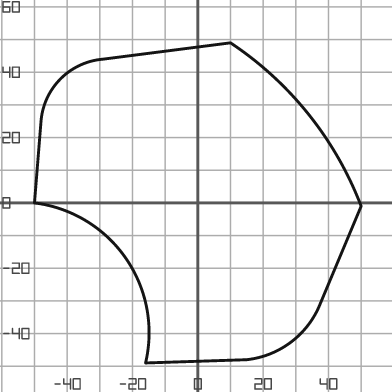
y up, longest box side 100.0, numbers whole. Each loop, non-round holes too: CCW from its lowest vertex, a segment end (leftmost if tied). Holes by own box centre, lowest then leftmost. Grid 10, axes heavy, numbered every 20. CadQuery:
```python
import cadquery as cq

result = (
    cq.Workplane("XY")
    .moveTo(-16.0, -49.0)
    .lineTo(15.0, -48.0)
    .threePointArc((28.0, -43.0), (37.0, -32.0))
    .lineTo(50.0, -1.0)
    .threePointArc((34.0, 27.0), (10.0, 49.0))
    .lineTo(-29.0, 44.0)
    .threePointArc((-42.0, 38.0), (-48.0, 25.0))
    .lineTo(-50.0, 0.0)
    .threePointArc((-22.0, -17.0), (-16.0, -49.0))
    .close()
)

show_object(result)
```